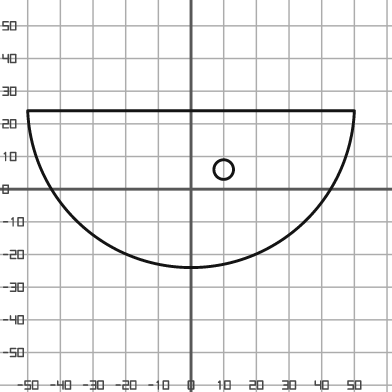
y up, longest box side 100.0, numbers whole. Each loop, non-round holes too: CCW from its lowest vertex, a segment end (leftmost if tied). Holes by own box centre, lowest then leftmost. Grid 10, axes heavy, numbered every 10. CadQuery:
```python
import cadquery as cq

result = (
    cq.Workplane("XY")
    .moveTo(-50.0, 24.0)
    .threePointArc((0.0, -24.0), (50.0, 24.0))
    .close()
    .moveTo(10.0, 6.0)
    .circle(3.0)
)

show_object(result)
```